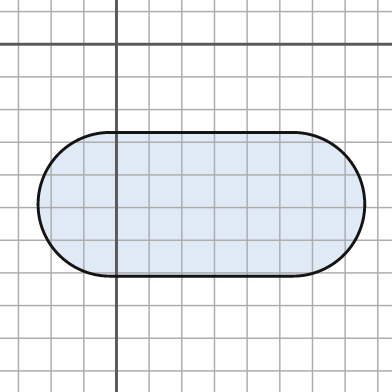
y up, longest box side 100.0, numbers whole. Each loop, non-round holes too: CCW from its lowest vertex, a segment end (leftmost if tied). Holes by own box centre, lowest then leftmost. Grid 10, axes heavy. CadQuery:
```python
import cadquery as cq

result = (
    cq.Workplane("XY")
    .moveTo(-2.0, -71.0)
    .lineTo(54.0, -71.0)
    .threePointArc((76.0, -49.0), (54.0, -27.0))
    .lineTo(-2.0, -27.0)
    .threePointArc((-24.0, -49.0), (-2.0, -71.0))
    .close()
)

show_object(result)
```